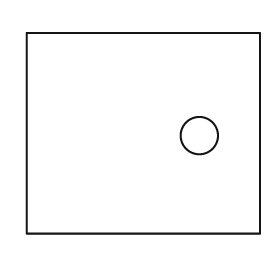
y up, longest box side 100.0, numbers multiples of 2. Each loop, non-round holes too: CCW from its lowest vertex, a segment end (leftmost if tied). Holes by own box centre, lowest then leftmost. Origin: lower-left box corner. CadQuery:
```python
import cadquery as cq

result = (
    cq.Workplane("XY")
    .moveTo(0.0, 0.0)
    .lineTo(100.0, 0.0)
    .lineTo(100.0, 86.0)
    .lineTo(0.0, 86.0)
    .close()
    .moveTo(74.0, 42.0)
    .circle(8.0)
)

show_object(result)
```